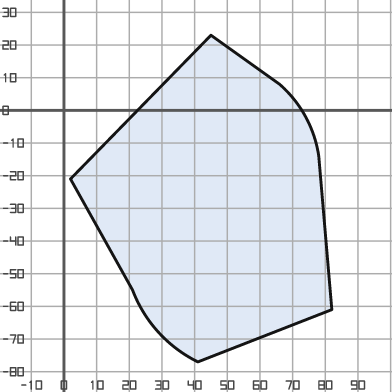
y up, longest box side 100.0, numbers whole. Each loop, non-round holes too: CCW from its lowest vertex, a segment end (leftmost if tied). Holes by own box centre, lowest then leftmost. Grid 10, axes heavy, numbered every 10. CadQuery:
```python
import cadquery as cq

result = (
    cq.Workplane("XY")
    .moveTo(41.0, -77.0)
    .lineTo(82.0, -61.0)
    .lineTo(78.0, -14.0)
    .threePointArc((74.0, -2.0), (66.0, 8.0))
    .lineTo(45.0, 23.0)
    .lineTo(2.0, -21.0)
    .lineTo(21.0, -55.0)
    .threePointArc((29.0, -68.0), (41.0, -77.0))
    .close()
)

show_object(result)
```